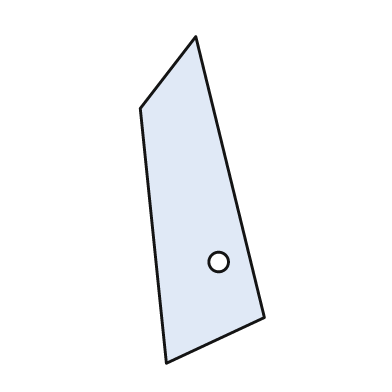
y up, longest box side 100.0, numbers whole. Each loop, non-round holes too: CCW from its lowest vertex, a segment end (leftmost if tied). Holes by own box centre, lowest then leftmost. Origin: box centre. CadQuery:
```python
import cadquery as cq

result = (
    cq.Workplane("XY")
    .moveTo(-11.0, -50.0)
    .lineTo(19.0, -36.0)
    .lineTo(-2.0, 50.0)
    .lineTo(-19.0, 28.0)
    .close()
    .moveTo(5.0, -19.0)
    .circle(3.0)
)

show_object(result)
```